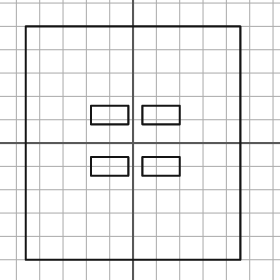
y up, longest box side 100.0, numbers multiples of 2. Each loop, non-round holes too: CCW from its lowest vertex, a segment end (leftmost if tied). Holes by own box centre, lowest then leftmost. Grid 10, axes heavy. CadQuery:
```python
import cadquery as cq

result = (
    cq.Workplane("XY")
    .moveTo(-46.0, -50.0)
    .lineTo(46.0, -50.0)
    .lineTo(46.0, 50.0)
    .lineTo(-46.0, 50.0)
    .close()
    .moveTo(-18.0, -14.0)
    .lineTo(-2.0, -14.0)
    .lineTo(-2.0, -6.0)
    .lineTo(-18.0, -6.0)
    .close()
    .moveTo(4.0, -14.0)
    .lineTo(20.0, -14.0)
    .lineTo(20.0, -6.0)
    .lineTo(4.0, -6.0)
    .close()
    .moveTo(-18.0, 8.0)
    .lineTo(-2.0, 8.0)
    .lineTo(-2.0, 16.0)
    .lineTo(-18.0, 16.0)
    .close()
    .moveTo(4.0, 8.0)
    .lineTo(20.0, 8.0)
    .lineTo(20.0, 16.0)
    .lineTo(4.0, 16.0)
    .close()
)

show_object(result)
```